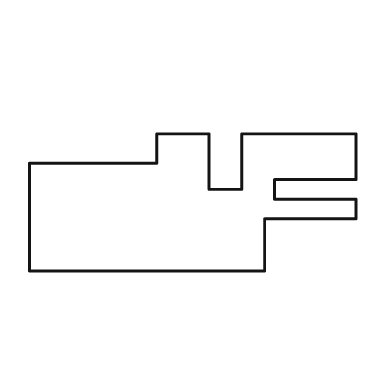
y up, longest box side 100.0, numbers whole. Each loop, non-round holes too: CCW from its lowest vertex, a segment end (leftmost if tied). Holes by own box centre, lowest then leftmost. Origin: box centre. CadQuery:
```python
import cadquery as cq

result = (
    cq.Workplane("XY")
    .moveTo(-50.0, -21.0)
    .lineTo(22.0, -21.0)
    .lineTo(22.0, -5.0)
    .lineTo(50.0, -5.0)
    .lineTo(50.0, 1.0)
    .lineTo(25.0, 1.0)
    .lineTo(25.0, 7.0)
    .lineTo(50.0, 7.0)
    .lineTo(50.0, 21.0)
    .lineTo(15.0, 21.0)
    .lineTo(15.0, 4.0)
    .lineTo(5.0, 4.0)
    .lineTo(5.0, 21.0)
    .lineTo(-11.0, 21.0)
    .lineTo(-11.0, 12.0)
    .lineTo(-50.0, 12.0)
    .close()
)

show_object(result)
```